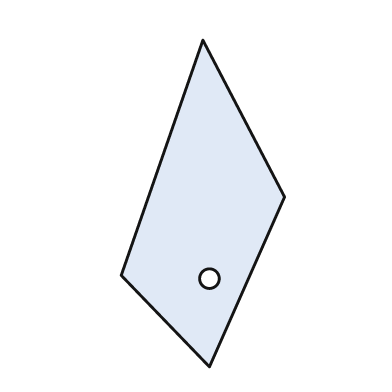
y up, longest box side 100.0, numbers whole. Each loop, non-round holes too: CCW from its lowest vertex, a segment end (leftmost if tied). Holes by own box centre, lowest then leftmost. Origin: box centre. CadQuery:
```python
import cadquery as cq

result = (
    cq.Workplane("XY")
    .moveTo(2.0, -50.0)
    .lineTo(25.0, 2.0)
    .lineTo(0.0, 50.0)
    .lineTo(-25.0, -22.0)
    .close()
    .moveTo(2.0, -23.0)
    .circle(3.0)
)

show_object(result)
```